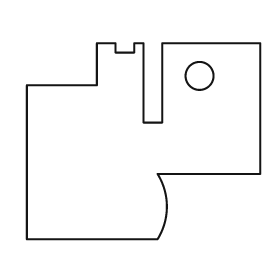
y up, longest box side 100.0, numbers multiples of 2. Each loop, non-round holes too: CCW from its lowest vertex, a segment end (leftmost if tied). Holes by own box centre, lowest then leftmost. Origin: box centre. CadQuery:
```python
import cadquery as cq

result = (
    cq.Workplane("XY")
    .moveTo(-50.0, -42.0)
    .lineTo(6.0, -42.0)
    .threePointArc((10.0, -28.0), (6.0, -14.0))
    .lineTo(50.0, -14.0)
    .lineTo(50.0, 42.0)
    .lineTo(8.0, 42.0)
    .lineTo(8.0, 8.0)
    .lineTo(0.0, 8.0)
    .lineTo(0.0, 42.0)
    .lineTo(-4.0, 42.0)
    .lineTo(-4.0, 38.0)
    .lineTo(-12.0, 38.0)
    .lineTo(-12.0, 42.0)
    .lineTo(-20.0, 42.0)
    .lineTo(-20.0, 24.0)
    .lineTo(-50.0, 24.0)
    .close()
    .moveTo(24.0, 28.0)
    .circle(6.0)
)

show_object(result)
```